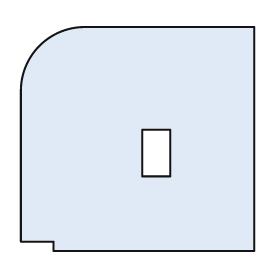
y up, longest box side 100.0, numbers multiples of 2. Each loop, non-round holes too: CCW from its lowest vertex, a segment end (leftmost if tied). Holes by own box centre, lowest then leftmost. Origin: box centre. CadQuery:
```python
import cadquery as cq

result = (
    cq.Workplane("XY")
    .moveTo(-36.0, -48.0)
    .lineTo(50.0, -48.0)
    .lineTo(50.0, 48.0)
    .lineTo(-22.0, 48.0)
    .threePointArc((-42.0, 40.0), (-50.0, 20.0))
    .lineTo(-50.0, -44.0)
    .lineTo(-36.0, -44.0)
    .close()
    .moveTo(2.0, -16.0)
    .lineTo(14.0, -16.0)
    .lineTo(14.0, 4.0)
    .lineTo(2.0, 4.0)
    .close()
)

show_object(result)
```